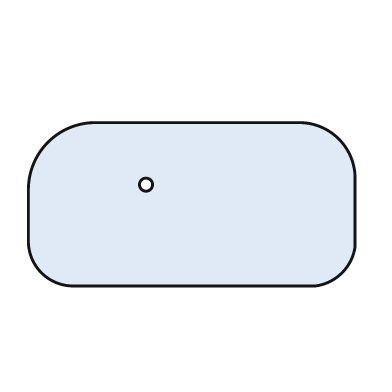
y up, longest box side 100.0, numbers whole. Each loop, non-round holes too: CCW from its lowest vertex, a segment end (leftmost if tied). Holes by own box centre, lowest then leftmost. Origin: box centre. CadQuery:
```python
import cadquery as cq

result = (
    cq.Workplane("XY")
    .moveTo(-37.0, -25.0)
    .lineTo(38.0, -25.0)
    .threePointArc((46.0, -21.0), (50.0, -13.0))
    .lineTo(50.0, 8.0)
    .threePointArc((45.0, 20.0), (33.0, 25.0))
    .lineTo(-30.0, 25.0)
    .threePointArc((-44.0, 19.0), (-50.0, 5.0))
    .lineTo(-50.0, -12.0)
    .threePointArc((-46.0, -21.0), (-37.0, -25.0))
    .close()
    .moveTo(-14.0, 6.0)
    .circle(2.0)
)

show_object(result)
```